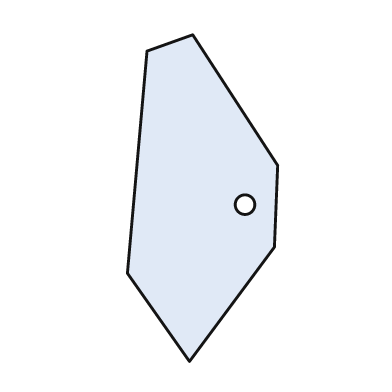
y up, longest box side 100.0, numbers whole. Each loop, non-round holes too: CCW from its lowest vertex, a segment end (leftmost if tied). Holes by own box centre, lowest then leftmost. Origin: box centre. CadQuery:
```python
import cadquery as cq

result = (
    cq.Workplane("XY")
    .moveTo(-4.0, -50.0)
    .lineTo(22.0, -15.0)
    .lineTo(23.0, 10.0)
    .lineTo(-3.0, 50.0)
    .lineTo(-17.0, 45.0)
    .lineTo(-23.0, -23.0)
    .close()
    .moveTo(13.0, -2.0)
    .circle(3.0)
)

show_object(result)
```